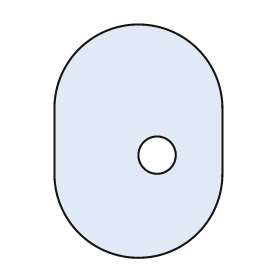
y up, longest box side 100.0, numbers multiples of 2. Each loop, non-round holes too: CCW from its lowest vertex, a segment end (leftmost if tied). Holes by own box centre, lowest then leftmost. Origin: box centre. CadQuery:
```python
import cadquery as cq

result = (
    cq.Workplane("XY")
    .moveTo(-36.0, -14.0)
    .threePointArc((0.0, -50.0), (36.0, -14.0))
    .lineTo(36.0, 14.0)
    .threePointArc((0.0, 50.0), (-36.0, 14.0))
    .close()
    .moveTo(8.0, -6.0)
    .circle(8.0)
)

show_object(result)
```